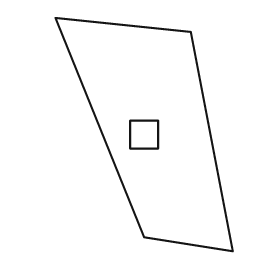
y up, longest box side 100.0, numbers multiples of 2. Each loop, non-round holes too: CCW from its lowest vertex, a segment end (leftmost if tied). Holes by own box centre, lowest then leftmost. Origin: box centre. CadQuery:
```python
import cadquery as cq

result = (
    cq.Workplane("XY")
    .moveTo(38.0, -50.0)
    .lineTo(20.0, 44.0)
    .lineTo(-38.0, 50.0)
    .lineTo(0.0, -44.0)
    .close()
    .moveTo(-6.0, -6.0)
    .lineTo(6.0, -6.0)
    .lineTo(6.0, 6.0)
    .lineTo(-6.0, 6.0)
    .close()
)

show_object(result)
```